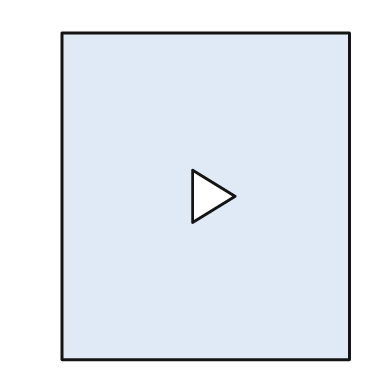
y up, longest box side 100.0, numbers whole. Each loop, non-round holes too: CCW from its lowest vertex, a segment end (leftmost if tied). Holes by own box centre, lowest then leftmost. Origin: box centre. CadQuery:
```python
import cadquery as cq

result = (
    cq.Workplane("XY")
    .moveTo(-44.0, -50.0)
    .lineTo(44.0, -50.0)
    .lineTo(44.0, 50.0)
    .lineTo(-44.0, 50.0)
    .close()
    .moveTo(-4.0, -8.0)
    .lineTo(9.0, 0.0)
    .lineTo(-4.0, 8.0)
    .close()
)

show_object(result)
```